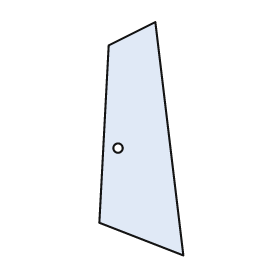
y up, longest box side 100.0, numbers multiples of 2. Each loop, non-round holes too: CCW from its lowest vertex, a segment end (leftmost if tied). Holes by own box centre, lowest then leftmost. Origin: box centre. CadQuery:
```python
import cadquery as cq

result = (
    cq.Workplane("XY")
    .moveTo(18.0, -50.0)
    .lineTo(6.0, 50.0)
    .lineTo(-14.0, 40.0)
    .lineTo(-18.0, -36.0)
    .close()
    .moveTo(-10.0, -4.0)
    .circle(2.0)
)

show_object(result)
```